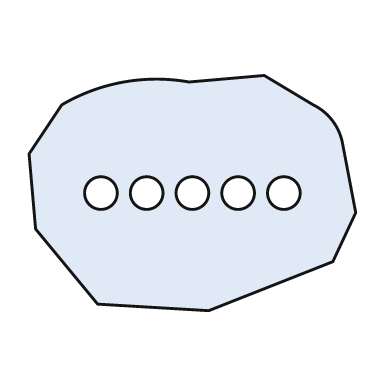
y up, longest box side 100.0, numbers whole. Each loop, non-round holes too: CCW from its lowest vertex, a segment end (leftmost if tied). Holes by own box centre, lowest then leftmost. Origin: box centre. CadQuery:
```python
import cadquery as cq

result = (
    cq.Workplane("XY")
    .moveTo(5.0, -36.0)
    .lineTo(43.0, -21.0)
    .lineTo(50.0, -6.0)
    .lineTo(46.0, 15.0)
    .threePointArc((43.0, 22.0), (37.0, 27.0))
    .lineTo(22.0, 36.0)
    .lineTo(-1.0, 34.0)
    .threePointArc((-21.0, 34.0), (-40.0, 27.0))
    .lineTo(-50.0, 12.0)
    .lineTo(-48.0, -11.0)
    .lineTo(-29.0, -34.0)
    .close()
    .moveTo(-28.0, 0.0)
    .circle(5.0)
    .moveTo(-14.0, 0.0)
    .circle(5.0)
    .moveTo(0.0, 0.0)
    .circle(5.0)
    .moveTo(14.0, 0.0)
    .circle(5.0)
    .moveTo(28.0, 0.0)
    .circle(5.0)
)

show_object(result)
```